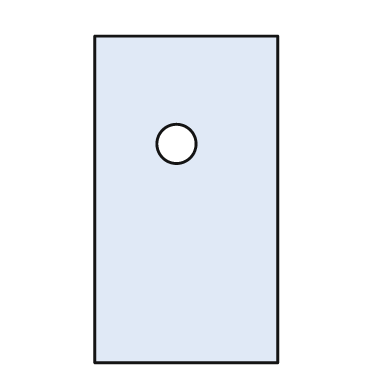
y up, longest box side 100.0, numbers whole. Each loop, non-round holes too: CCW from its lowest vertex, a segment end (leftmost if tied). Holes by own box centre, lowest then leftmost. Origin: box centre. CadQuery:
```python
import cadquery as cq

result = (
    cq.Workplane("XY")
    .moveTo(-28.0, -50.0)
    .lineTo(28.0, -50.0)
    .lineTo(28.0, 50.0)
    .lineTo(-28.0, 50.0)
    .close()
    .moveTo(-3.0, 17.0)
    .circle(6.0)
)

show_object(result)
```